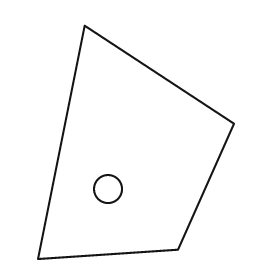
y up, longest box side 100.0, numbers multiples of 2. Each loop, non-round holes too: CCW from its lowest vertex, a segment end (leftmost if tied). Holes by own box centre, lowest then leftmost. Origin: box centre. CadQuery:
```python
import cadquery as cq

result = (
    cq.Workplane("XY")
    .moveTo(-42.0, -50.0)
    .lineTo(18.0, -46.0)
    .lineTo(42.0, 8.0)
    .lineTo(-22.0, 50.0)
    .close()
    .moveTo(-12.0, -20.0)
    .circle(6.0)
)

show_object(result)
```